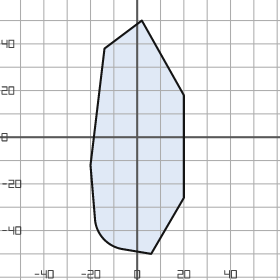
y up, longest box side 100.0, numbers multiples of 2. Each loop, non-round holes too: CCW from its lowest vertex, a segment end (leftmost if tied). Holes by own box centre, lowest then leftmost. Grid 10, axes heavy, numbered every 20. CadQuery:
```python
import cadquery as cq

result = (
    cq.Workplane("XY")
    .moveTo(6.0, -50.0)
    .lineTo(20.0, -26.0)
    .lineTo(20.0, 18.0)
    .lineTo(2.0, 50.0)
    .lineTo(-14.0, 38.0)
    .lineTo(-20.0, -12.0)
    .lineTo(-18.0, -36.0)
    .threePointArc((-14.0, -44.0), (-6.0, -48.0))
    .close()
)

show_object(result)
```